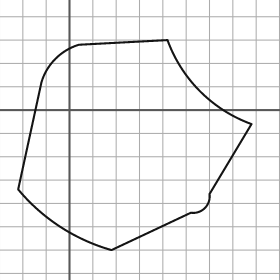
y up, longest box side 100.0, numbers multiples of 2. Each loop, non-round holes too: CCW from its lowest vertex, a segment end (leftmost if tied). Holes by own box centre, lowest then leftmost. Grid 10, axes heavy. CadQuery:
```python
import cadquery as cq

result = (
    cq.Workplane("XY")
    .moveTo(18.0, -60.0)
    .lineTo(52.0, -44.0)
    .threePointArc((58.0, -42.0), (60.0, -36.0))
    .lineTo(78.0, -6.0)
    .threePointArc((56.0, 8.0), (42.0, 30.0))
    .lineTo(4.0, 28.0)
    .threePointArc((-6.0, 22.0), (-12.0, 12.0))
    .lineTo(-22.0, -34.0)
    .threePointArc((-4.0, -50.0), (18.0, -60.0))
    .close()
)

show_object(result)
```